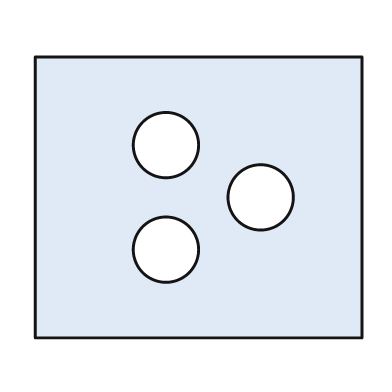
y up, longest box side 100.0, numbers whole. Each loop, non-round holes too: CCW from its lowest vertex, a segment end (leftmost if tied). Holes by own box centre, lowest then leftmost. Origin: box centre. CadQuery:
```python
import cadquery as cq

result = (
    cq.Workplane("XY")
    .moveTo(-50.0, -43.0)
    .lineTo(50.0, -43.0)
    .lineTo(50.0, 43.0)
    .lineTo(-50.0, 43.0)
    .close()
    .moveTo(-10.0, -16.0)
    .circle(10.0)
    .moveTo(19.0, 0.0)
    .circle(10.0)
    .moveTo(-10.0, 16.0)
    .circle(10.0)
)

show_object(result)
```